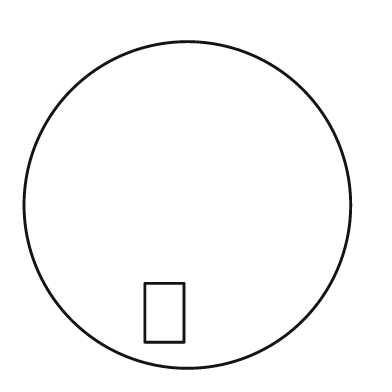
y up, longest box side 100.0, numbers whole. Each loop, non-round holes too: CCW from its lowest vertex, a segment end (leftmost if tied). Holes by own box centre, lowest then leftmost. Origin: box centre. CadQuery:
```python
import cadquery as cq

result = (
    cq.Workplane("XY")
    .moveTo(0.0, 0.0)
    .circle(50.0)
    .moveTo(-13.0, -42.0)
    .lineTo(-1.0, -42.0)
    .lineTo(-1.0, -24.0)
    .lineTo(-13.0, -24.0)
    .close()
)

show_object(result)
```